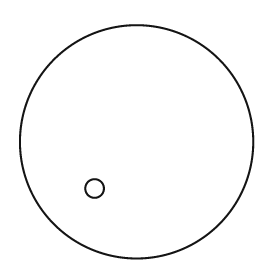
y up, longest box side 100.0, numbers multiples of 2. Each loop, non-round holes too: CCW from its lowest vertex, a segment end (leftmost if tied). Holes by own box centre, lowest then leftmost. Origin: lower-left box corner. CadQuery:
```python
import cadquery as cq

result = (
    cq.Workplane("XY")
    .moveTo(50.0, 50.0)
    .circle(50.0)
    .moveTo(32.0, 30.0)
    .circle(4.0)
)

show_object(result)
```